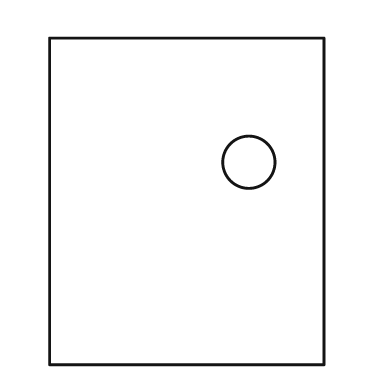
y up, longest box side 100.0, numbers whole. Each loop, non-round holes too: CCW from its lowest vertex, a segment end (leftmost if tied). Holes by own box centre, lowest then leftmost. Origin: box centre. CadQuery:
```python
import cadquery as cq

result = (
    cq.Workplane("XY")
    .moveTo(-42.0, -50.0)
    .lineTo(42.0, -50.0)
    .lineTo(42.0, 50.0)
    .lineTo(-42.0, 50.0)
    .close()
    .moveTo(19.0, 12.0)
    .circle(8.0)
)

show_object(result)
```